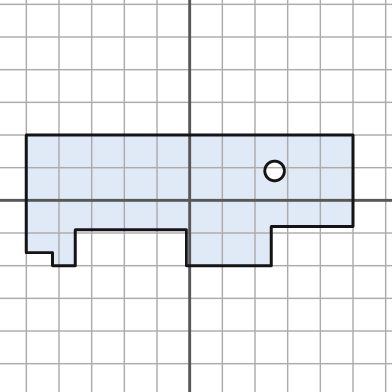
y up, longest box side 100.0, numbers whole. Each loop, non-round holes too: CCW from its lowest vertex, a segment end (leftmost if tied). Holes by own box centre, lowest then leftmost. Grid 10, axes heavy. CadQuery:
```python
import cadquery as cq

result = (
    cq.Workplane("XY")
    .moveTo(-42.0, -20.0)
    .lineTo(-35.0, -20.0)
    .lineTo(-35.0, -9.0)
    .lineTo(-1.0, -9.0)
    .lineTo(-1.0, -20.0)
    .lineTo(25.0, -20.0)
    .lineTo(25.0, -8.0)
    .lineTo(50.0, -8.0)
    .lineTo(50.0, 20.0)
    .lineTo(-50.0, 20.0)
    .lineTo(-50.0, -16.0)
    .lineTo(-42.0, -16.0)
    .close()
    .moveTo(26.0, 9.0)
    .circle(3.0)
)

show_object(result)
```